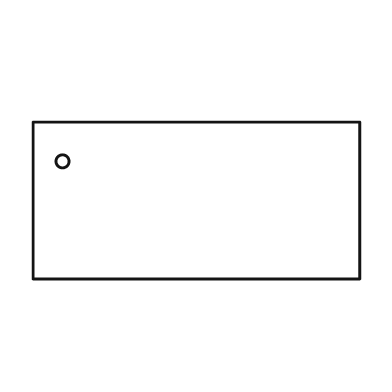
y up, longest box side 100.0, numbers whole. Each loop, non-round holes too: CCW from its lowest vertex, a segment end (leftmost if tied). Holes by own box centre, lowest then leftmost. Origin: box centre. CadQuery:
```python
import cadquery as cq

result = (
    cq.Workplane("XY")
    .moveTo(-50.0, -24.0)
    .lineTo(50.0, -24.0)
    .lineTo(50.0, 24.0)
    .lineTo(-50.0, 24.0)
    .close()
    .moveTo(-41.0, 12.0)
    .circle(2.0)
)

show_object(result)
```